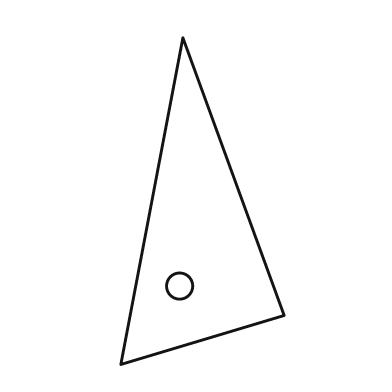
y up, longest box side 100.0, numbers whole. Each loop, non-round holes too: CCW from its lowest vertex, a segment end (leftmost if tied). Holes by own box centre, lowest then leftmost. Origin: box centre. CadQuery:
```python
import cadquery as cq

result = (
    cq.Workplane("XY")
    .moveTo(-25.0, -50.0)
    .lineTo(25.0, -35.0)
    .lineTo(-6.0, 50.0)
    .close()
    .moveTo(-7.0, -26.0)
    .circle(4.0)
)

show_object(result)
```